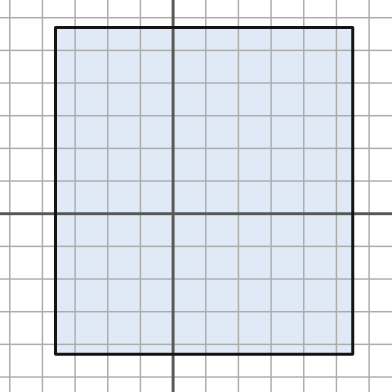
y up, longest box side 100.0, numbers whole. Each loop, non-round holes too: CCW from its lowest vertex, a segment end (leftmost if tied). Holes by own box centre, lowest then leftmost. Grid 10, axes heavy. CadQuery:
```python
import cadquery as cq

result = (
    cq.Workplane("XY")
    .moveTo(-36.0, -43.0)
    .lineTo(55.0, -43.0)
    .lineTo(55.0, 57.0)
    .lineTo(-36.0, 57.0)
    .close()
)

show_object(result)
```